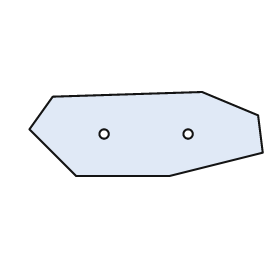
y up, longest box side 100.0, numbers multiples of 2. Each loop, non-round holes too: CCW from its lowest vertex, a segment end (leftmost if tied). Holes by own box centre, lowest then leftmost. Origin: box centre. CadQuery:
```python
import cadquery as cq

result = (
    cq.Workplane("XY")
    .moveTo(-30.0, -18.0)
    .lineTo(10.0, -18.0)
    .lineTo(50.0, -8.0)
    .lineTo(48.0, 8.0)
    .lineTo(24.0, 18.0)
    .lineTo(-40.0, 16.0)
    .lineTo(-50.0, 2.0)
    .close()
    .moveTo(-18.0, 0.0)
    .circle(2.0)
    .moveTo(18.0, 0.0)
    .circle(2.0)
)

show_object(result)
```